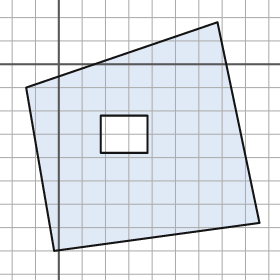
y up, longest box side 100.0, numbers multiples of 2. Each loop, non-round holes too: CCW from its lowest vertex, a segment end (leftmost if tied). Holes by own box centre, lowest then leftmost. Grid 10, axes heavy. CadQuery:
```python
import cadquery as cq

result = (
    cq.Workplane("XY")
    .moveTo(-2.0, -80.0)
    .lineTo(86.0, -68.0)
    .lineTo(68.0, 18.0)
    .lineTo(-14.0, -10.0)
    .close()
    .moveTo(18.0, -38.0)
    .lineTo(38.0, -38.0)
    .lineTo(38.0, -22.0)
    .lineTo(18.0, -22.0)
    .close()
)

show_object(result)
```